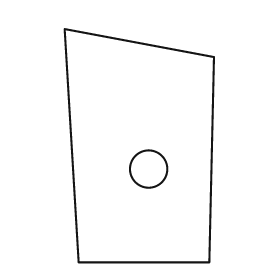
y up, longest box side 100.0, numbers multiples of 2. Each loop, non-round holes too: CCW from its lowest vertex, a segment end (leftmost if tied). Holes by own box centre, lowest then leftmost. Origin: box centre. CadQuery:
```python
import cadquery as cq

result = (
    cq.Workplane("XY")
    .moveTo(-26.0, -50.0)
    .lineTo(30.0, -50.0)
    .lineTo(32.0, 38.0)
    .lineTo(-32.0, 50.0)
    .close()
    .moveTo(4.0, -10.0)
    .circle(8.0)
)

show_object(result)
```